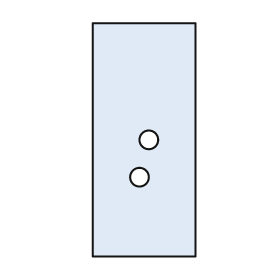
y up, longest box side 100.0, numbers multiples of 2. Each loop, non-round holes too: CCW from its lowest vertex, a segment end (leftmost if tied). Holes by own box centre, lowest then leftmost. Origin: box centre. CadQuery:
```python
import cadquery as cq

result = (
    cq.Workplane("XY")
    .moveTo(-22.0, -50.0)
    .lineTo(22.0, -50.0)
    .lineTo(22.0, 50.0)
    .lineTo(-22.0, 50.0)
    .close()
    .moveTo(-2.0, -16.0)
    .circle(4.0)
    .moveTo(2.0, 0.0)
    .circle(4.0)
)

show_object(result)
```